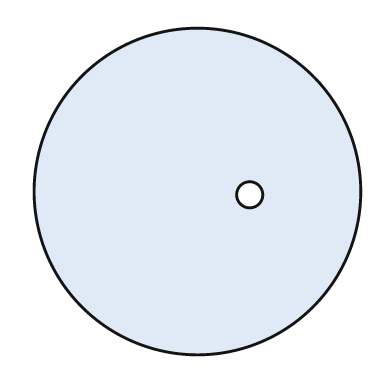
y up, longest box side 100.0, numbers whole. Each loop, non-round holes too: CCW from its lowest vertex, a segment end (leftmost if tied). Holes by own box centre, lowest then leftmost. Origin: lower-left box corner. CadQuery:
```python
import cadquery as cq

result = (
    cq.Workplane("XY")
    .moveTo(50.0, 50.0)
    .circle(50.0)
    .moveTo(66.0, 49.0)
    .circle(4.0)
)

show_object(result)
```